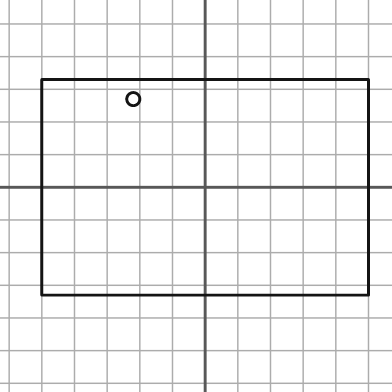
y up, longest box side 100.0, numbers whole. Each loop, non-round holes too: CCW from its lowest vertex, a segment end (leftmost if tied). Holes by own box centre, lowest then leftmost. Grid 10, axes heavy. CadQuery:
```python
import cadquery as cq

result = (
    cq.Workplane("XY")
    .moveTo(-50.0, -33.0)
    .lineTo(50.0, -33.0)
    .lineTo(50.0, 33.0)
    .lineTo(-50.0, 33.0)
    .close()
    .moveTo(-22.0, 27.0)
    .circle(2.0)
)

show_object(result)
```